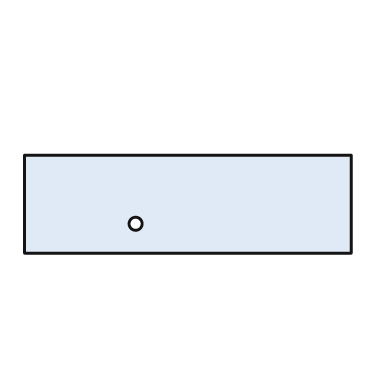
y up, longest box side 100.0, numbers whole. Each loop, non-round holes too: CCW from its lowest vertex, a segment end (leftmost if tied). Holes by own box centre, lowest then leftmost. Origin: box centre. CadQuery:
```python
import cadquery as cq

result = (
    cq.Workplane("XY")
    .moveTo(-50.0, -15.0)
    .lineTo(50.0, -15.0)
    .lineTo(50.0, 15.0)
    .lineTo(-50.0, 15.0)
    .close()
    .moveTo(-16.0, -6.0)
    .circle(2.0)
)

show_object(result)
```